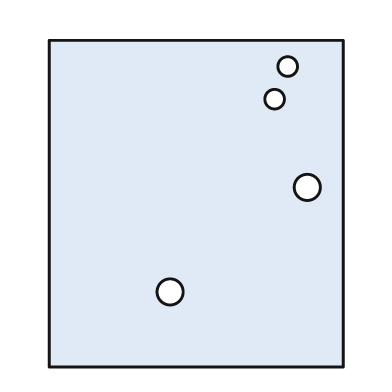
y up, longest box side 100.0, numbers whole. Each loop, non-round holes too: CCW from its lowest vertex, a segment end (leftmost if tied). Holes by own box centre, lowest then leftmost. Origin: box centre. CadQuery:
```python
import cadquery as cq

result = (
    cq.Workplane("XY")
    .moveTo(-45.0, -50.0)
    .lineTo(45.0, -50.0)
    .lineTo(45.0, 50.0)
    .lineTo(-45.0, 50.0)
    .close()
    .moveTo(-8.0, -27.0)
    .circle(4.0)
    .moveTo(34.0, 5.0)
    .circle(4.0)
    .moveTo(24.0, 32.0)
    .circle(3.0)
    .moveTo(28.0, 42.0)
    .circle(3.0)
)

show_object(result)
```